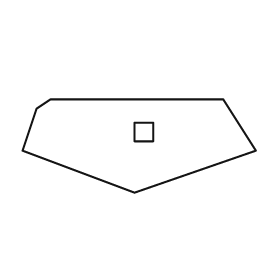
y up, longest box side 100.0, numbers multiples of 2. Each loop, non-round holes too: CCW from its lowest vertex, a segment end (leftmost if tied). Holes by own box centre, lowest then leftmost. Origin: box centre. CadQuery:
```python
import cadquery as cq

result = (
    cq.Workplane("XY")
    .moveTo(-2.0, -20.0)
    .lineTo(50.0, -2.0)
    .lineTo(36.0, 20.0)
    .lineTo(-38.0, 20.0)
    .lineTo(-44.0, 16.0)
    .lineTo(-50.0, -2.0)
    .close()
    .moveTo(-2.0, 2.0)
    .lineTo(6.0, 2.0)
    .lineTo(6.0, 10.0)
    .lineTo(-2.0, 10.0)
    .close()
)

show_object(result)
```